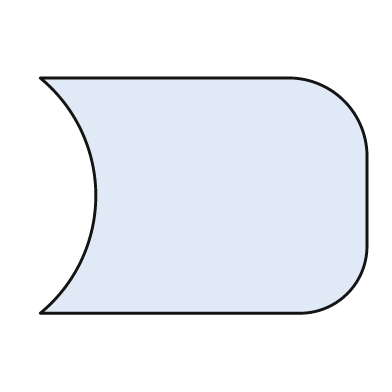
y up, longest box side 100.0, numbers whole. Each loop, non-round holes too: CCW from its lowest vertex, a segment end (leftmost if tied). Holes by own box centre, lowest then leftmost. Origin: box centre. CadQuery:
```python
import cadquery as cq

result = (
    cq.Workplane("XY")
    .moveTo(-50.0, -36.0)
    .lineTo(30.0, -36.0)
    .threePointArc((44.0, -30.0), (50.0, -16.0))
    .lineTo(50.0, 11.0)
    .threePointArc((43.0, 29.0), (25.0, 36.0))
    .lineTo(-50.0, 36.0)
    .threePointArc((-33.0, 0.0), (-50.0, -36.0))
    .close()
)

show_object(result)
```